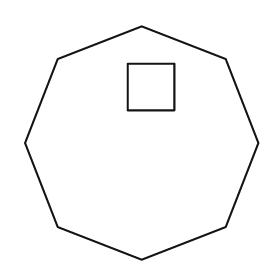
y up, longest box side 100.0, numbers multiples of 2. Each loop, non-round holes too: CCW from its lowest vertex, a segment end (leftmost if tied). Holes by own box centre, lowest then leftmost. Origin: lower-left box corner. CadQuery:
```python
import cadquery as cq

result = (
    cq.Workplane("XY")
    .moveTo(50.0, 0.0)
    .lineTo(86.0, 14.0)
    .lineTo(100.0, 50.0)
    .lineTo(86.0, 86.0)
    .lineTo(50.0, 100.0)
    .lineTo(14.0, 86.0)
    .lineTo(0.0, 50.0)
    .lineTo(14.0, 14.0)
    .close()
    .moveTo(44.0, 64.0)
    .lineTo(64.0, 64.0)
    .lineTo(64.0, 84.0)
    .lineTo(44.0, 84.0)
    .close()
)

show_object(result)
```